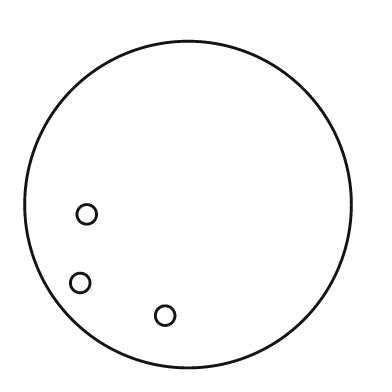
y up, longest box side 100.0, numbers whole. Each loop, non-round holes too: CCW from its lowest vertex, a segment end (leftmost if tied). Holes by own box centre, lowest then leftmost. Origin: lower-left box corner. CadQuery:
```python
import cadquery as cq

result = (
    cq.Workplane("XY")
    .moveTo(50.0, 50.0)
    .circle(50.0)
    .moveTo(43.0, 16.0)
    .circle(3.0)
    .moveTo(17.0, 26.0)
    .circle(3.0)
    .moveTo(19.0, 47.0)
    .circle(3.0)
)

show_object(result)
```